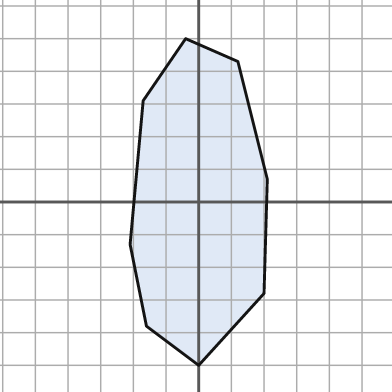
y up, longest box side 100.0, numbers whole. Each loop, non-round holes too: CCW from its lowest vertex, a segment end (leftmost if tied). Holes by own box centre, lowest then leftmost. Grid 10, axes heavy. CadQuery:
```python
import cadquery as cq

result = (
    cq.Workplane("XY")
    .moveTo(0.0, -50.0)
    .lineTo(20.0, -28.0)
    .lineTo(21.0, 7.0)
    .lineTo(12.0, 43.0)
    .lineTo(-4.0, 50.0)
    .lineTo(-17.0, 31.0)
    .lineTo(-21.0, -13.0)
    .lineTo(-16.0, -38.0)
    .close()
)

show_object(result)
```